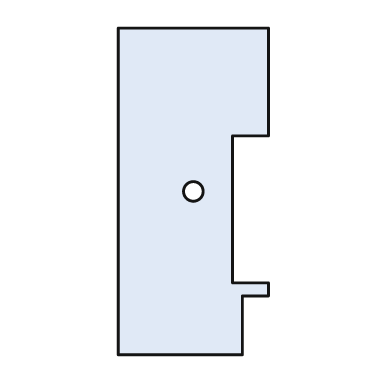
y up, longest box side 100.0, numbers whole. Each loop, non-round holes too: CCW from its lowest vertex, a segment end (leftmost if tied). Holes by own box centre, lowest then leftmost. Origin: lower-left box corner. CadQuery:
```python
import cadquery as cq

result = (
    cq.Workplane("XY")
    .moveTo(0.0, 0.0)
    .lineTo(38.0, 0.0)
    .lineTo(38.0, 18.0)
    .lineTo(46.0, 18.0)
    .lineTo(46.0, 22.0)
    .lineTo(35.0, 22.0)
    .lineTo(35.0, 67.0)
    .lineTo(46.0, 67.0)
    .lineTo(46.0, 100.0)
    .lineTo(0.0, 100.0)
    .close()
    .moveTo(23.0, 50.0)
    .circle(3.0)
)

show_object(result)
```